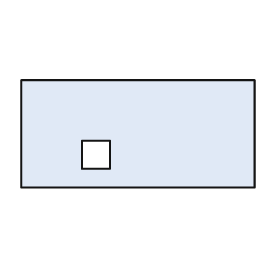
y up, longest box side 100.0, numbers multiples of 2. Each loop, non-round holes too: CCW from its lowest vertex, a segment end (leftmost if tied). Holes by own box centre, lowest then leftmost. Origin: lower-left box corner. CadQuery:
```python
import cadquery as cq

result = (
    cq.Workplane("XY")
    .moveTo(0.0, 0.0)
    .lineTo(100.0, 0.0)
    .lineTo(100.0, 46.0)
    .lineTo(0.0, 46.0)
    .close()
    .moveTo(26.0, 8.0)
    .lineTo(38.0, 8.0)
    .lineTo(38.0, 20.0)
    .lineTo(26.0, 20.0)
    .close()
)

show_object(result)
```